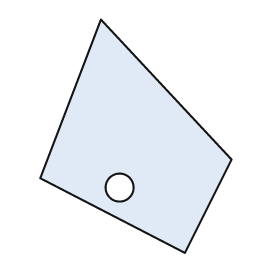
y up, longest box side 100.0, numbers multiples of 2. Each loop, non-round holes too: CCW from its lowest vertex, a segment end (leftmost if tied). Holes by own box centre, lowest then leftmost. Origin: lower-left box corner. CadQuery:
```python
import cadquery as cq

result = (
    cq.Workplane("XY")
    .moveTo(62.0, 0.0)
    .lineTo(82.0, 40.0)
    .lineTo(26.0, 100.0)
    .lineTo(0.0, 32.0)
    .close()
    .moveTo(34.0, 28.0)
    .circle(6.0)
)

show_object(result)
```